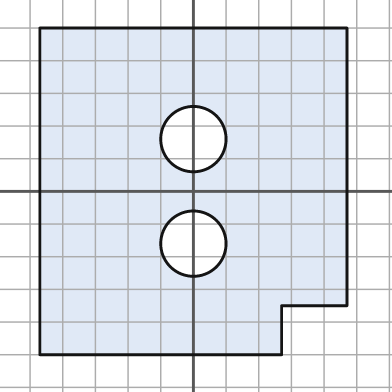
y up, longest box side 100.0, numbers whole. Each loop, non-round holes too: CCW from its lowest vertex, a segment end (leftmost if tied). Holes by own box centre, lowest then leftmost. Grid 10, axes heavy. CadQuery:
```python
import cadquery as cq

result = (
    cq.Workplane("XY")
    .moveTo(-47.0, -50.0)
    .lineTo(27.0, -50.0)
    .lineTo(27.0, -35.0)
    .lineTo(47.0, -35.0)
    .lineTo(47.0, 50.0)
    .lineTo(-47.0, 50.0)
    .close()
    .moveTo(0.0, -16.0)
    .circle(10.0)
    .moveTo(0.0, 16.0)
    .circle(10.0)
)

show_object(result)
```